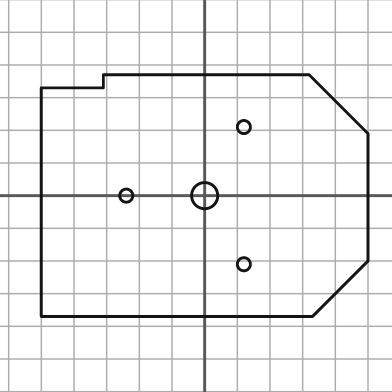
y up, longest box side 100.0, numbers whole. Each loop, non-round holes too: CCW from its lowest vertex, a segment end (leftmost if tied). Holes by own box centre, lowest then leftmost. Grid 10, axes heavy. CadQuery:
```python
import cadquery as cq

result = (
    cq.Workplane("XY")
    .moveTo(-50.0, -37.0)
    .lineTo(33.0, -37.0)
    .lineTo(50.0, -20.0)
    .lineTo(50.0, 19.0)
    .lineTo(32.0, 37.0)
    .lineTo(-31.0, 37.0)
    .lineTo(-31.0, 33.0)
    .lineTo(-50.0, 33.0)
    .close()
    .moveTo(12.0, -21.0)
    .circle(2.0)
    .moveTo(-24.0, 0.0)
    .circle(2.0)
    .moveTo(0.0, 0.0)
    .circle(4.0)
    .moveTo(12.0, 21.0)
    .circle(2.0)
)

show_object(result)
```